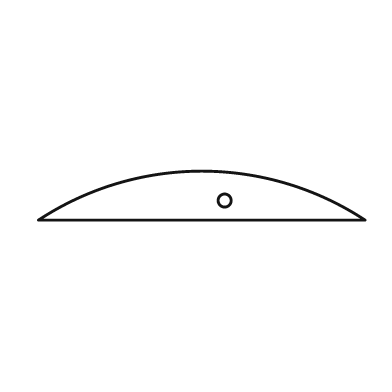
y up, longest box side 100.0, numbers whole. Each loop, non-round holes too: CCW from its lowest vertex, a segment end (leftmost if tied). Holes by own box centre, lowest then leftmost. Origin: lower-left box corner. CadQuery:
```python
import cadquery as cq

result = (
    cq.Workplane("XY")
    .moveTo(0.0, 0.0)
    .lineTo(100.0, 0.0)
    .threePointArc((50.0, 15.0), (0.0, 0.0))
    .close()
    .moveTo(57.0, 6.0)
    .circle(2.0)
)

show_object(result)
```